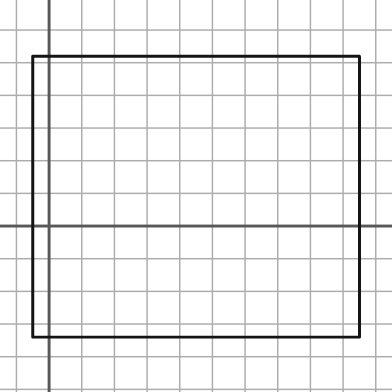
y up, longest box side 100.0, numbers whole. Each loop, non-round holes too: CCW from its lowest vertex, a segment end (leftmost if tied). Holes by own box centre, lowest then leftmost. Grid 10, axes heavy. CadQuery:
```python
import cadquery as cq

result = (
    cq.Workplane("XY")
    .moveTo(-5.0, -34.0)
    .lineTo(95.0, -34.0)
    .lineTo(95.0, 52.0)
    .lineTo(-5.0, 52.0)
    .close()
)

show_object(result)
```